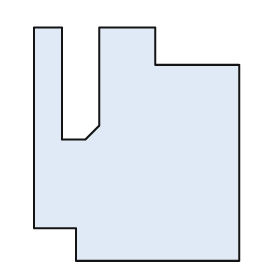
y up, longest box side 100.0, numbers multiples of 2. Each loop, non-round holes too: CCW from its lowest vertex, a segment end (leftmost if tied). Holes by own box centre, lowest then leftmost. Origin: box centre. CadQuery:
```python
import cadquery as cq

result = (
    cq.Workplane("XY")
    .moveTo(-26.0, -50.0)
    .lineTo(44.0, -50.0)
    .lineTo(44.0, 34.0)
    .lineTo(8.0, 34.0)
    .lineTo(8.0, 50.0)
    .lineTo(-16.0, 50.0)
    .lineTo(-16.0, 8.0)
    .lineTo(-22.0, 2.0)
    .lineTo(-32.0, 2.0)
    .lineTo(-32.0, 50.0)
    .lineTo(-44.0, 50.0)
    .lineTo(-44.0, -36.0)
    .lineTo(-26.0, -36.0)
    .close()
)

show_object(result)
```